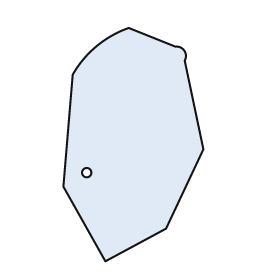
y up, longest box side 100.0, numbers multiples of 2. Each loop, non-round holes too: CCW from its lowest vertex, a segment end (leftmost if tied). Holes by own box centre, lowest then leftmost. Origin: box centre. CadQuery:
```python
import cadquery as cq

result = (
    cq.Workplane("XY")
    .moveTo(-12.0, -50.0)
    .lineTo(14.0, -36.0)
    .lineTo(30.0, -2.0)
    .lineTo(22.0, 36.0)
    .threePointArc((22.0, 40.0), (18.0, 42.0))
    .lineTo(-2.0, 50.0)
    .threePointArc((-16.0, 42.0), (-26.0, 30.0))
    .lineTo(-30.0, -18.0)
    .close()
    .moveTo(-20.0, -12.0)
    .circle(2.0)
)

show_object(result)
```